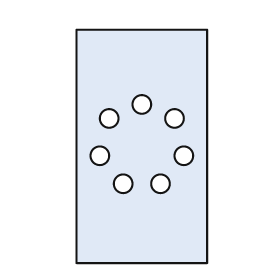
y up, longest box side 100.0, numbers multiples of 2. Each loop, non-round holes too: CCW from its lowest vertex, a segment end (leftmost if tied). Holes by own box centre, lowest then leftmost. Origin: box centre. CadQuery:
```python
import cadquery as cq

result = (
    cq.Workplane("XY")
    .moveTo(-28.0, -50.0)
    .lineTo(28.0, -50.0)
    .lineTo(28.0, 50.0)
    .lineTo(-28.0, 50.0)
    .close()
    .moveTo(-8.0, -16.0)
    .circle(4.0)
    .moveTo(8.0, -16.0)
    .circle(4.0)
    .moveTo(-18.0, -4.0)
    .circle(4.0)
    .moveTo(18.0, -4.0)
    .circle(4.0)
    .moveTo(-14.0, 12.0)
    .circle(4.0)
    .moveTo(14.0, 12.0)
    .circle(4.0)
    .moveTo(0.0, 18.0)
    .circle(4.0)
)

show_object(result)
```